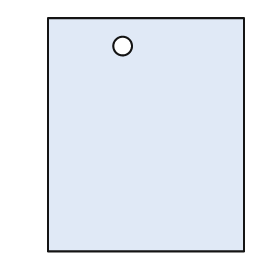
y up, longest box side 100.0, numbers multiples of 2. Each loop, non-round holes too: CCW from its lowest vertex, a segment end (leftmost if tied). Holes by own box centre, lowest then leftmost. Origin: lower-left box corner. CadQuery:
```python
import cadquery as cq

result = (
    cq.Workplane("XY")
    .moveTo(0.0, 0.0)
    .lineTo(84.0, 0.0)
    .lineTo(84.0, 100.0)
    .lineTo(0.0, 100.0)
    .close()
    .moveTo(32.0, 88.0)
    .circle(4.0)
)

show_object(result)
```